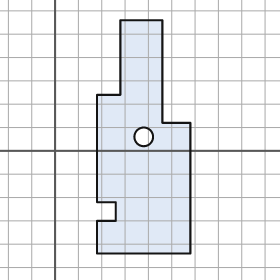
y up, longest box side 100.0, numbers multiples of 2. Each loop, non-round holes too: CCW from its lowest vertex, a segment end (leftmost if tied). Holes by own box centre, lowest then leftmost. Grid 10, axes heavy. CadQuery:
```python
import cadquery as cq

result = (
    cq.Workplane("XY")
    .moveTo(18.0, -44.0)
    .lineTo(58.0, -44.0)
    .lineTo(58.0, 12.0)
    .lineTo(46.0, 12.0)
    .lineTo(46.0, 56.0)
    .lineTo(28.0, 56.0)
    .lineTo(28.0, 24.0)
    .lineTo(18.0, 24.0)
    .lineTo(18.0, -22.0)
    .lineTo(26.0, -22.0)
    .lineTo(26.0, -30.0)
    .lineTo(18.0, -30.0)
    .close()
    .moveTo(38.0, 6.0)
    .circle(4.0)
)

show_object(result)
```